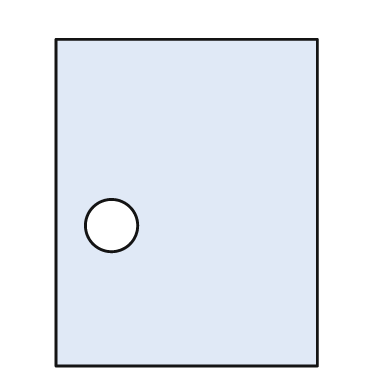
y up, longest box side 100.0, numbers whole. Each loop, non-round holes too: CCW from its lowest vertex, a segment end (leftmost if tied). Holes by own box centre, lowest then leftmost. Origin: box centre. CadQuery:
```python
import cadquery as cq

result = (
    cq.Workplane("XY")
    .moveTo(-40.0, -50.0)
    .lineTo(40.0, -50.0)
    .lineTo(40.0, 50.0)
    .lineTo(-40.0, 50.0)
    .close()
    .moveTo(-23.0, -7.0)
    .circle(8.0)
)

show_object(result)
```